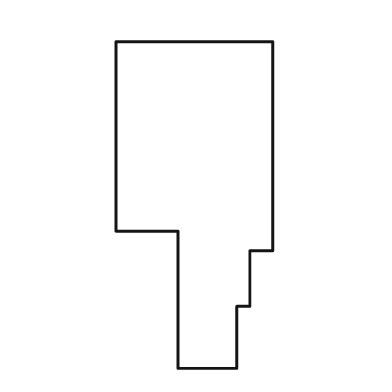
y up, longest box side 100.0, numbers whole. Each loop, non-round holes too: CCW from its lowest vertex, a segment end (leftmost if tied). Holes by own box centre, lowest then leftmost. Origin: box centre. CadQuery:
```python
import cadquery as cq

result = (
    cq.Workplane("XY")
    .moveTo(-5.0, -50.0)
    .lineTo(13.0, -50.0)
    .lineTo(13.0, -31.0)
    .lineTo(17.0, -31.0)
    .lineTo(17.0, -14.0)
    .lineTo(24.0, -14.0)
    .lineTo(24.0, 50.0)
    .lineTo(-24.0, 50.0)
    .lineTo(-24.0, -8.0)
    .lineTo(-5.0, -8.0)
    .close()
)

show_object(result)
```